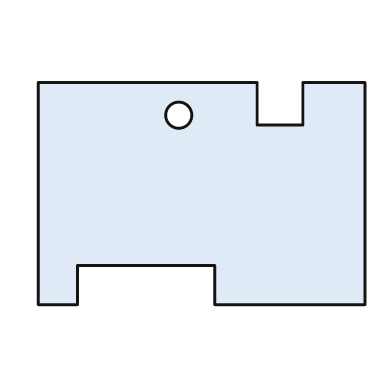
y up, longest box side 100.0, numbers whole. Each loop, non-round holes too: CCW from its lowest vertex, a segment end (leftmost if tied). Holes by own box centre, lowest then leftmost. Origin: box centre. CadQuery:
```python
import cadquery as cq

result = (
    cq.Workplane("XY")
    .moveTo(-50.0, -34.0)
    .lineTo(-38.0, -34.0)
    .lineTo(-38.0, -22.0)
    .lineTo(4.0, -22.0)
    .lineTo(4.0, -34.0)
    .lineTo(50.0, -34.0)
    .lineTo(50.0, 34.0)
    .lineTo(31.0, 34.0)
    .lineTo(31.0, 21.0)
    .lineTo(17.0, 21.0)
    .lineTo(17.0, 34.0)
    .lineTo(-50.0, 34.0)
    .close()
    .moveTo(-7.0, 24.0)
    .circle(4.0)
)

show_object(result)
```